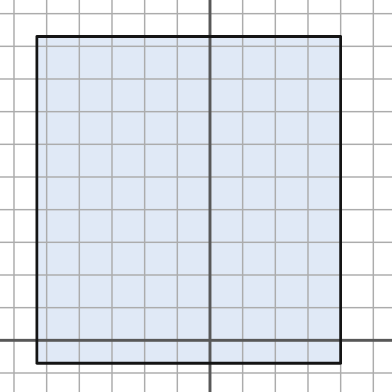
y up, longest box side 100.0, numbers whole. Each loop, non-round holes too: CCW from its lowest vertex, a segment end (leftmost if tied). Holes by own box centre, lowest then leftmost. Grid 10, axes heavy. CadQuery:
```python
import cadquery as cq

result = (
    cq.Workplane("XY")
    .moveTo(-53.0, -7.0)
    .lineTo(40.0, -7.0)
    .lineTo(40.0, 93.0)
    .lineTo(-53.0, 93.0)
    .close()
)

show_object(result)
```